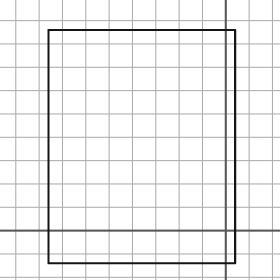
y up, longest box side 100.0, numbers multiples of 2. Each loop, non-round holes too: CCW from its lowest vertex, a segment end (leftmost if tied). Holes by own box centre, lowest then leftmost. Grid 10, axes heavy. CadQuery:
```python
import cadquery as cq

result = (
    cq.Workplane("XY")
    .moveTo(-76.0, -14.0)
    .lineTo(4.0, -14.0)
    .lineTo(4.0, 86.0)
    .lineTo(-76.0, 86.0)
    .close()
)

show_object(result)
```